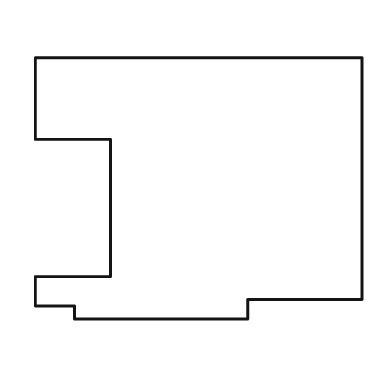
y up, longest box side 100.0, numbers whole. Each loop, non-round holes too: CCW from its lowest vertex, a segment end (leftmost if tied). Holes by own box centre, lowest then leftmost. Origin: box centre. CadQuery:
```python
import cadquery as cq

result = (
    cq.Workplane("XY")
    .moveTo(-38.0, -40.0)
    .lineTo(15.0, -40.0)
    .lineTo(15.0, -34.0)
    .lineTo(50.0, -34.0)
    .lineTo(50.0, 40.0)
    .lineTo(-50.0, 40.0)
    .lineTo(-50.0, 15.0)
    .lineTo(-27.0, 15.0)
    .lineTo(-27.0, -27.0)
    .lineTo(-50.0, -27.0)
    .lineTo(-50.0, -36.0)
    .lineTo(-38.0, -36.0)
    .close()
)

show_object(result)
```